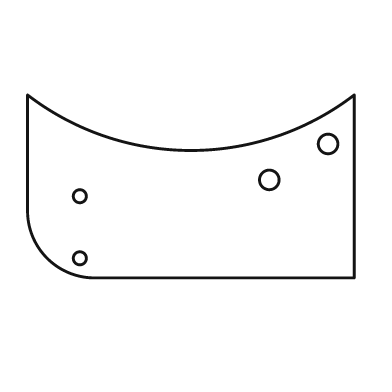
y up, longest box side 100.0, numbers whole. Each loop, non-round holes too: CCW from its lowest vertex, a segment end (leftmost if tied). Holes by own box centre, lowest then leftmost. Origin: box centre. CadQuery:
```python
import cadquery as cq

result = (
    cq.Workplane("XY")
    .moveTo(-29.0, -28.0)
    .lineTo(50.0, -28.0)
    .lineTo(50.0, 28.0)
    .threePointArc((0.0, 11.0), (-50.0, 28.0))
    .lineTo(-50.0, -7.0)
    .threePointArc((-44.0, -22.0), (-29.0, -28.0))
    .close()
    .moveTo(-34.0, -22.0)
    .circle(2.0)
    .moveTo(-34.0, -3.0)
    .circle(2.0)
    .moveTo(24.0, 2.0)
    .circle(3.0)
    .moveTo(42.0, 13.0)
    .circle(3.0)
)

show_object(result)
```